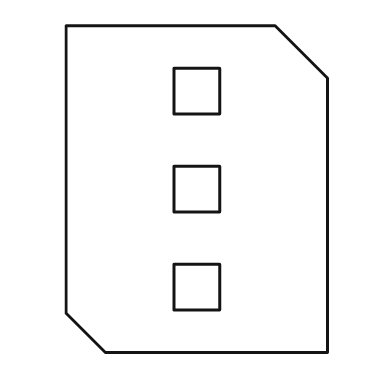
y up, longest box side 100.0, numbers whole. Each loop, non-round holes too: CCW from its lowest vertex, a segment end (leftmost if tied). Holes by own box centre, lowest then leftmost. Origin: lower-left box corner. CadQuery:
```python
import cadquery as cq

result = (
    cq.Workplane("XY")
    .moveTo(12.0, 0.0)
    .lineTo(80.0, 0.0)
    .lineTo(80.0, 84.0)
    .lineTo(64.0, 100.0)
    .lineTo(0.0, 100.0)
    .lineTo(0.0, 12.0)
    .close()
    .moveTo(33.0, 13.0)
    .lineTo(47.0, 13.0)
    .lineTo(47.0, 27.0)
    .lineTo(33.0, 27.0)
    .close()
    .moveTo(33.0, 43.0)
    .lineTo(47.0, 43.0)
    .lineTo(47.0, 57.0)
    .lineTo(33.0, 57.0)
    .close()
    .moveTo(33.0, 73.0)
    .lineTo(47.0, 73.0)
    .lineTo(47.0, 87.0)
    .lineTo(33.0, 87.0)
    .close()
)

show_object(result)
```